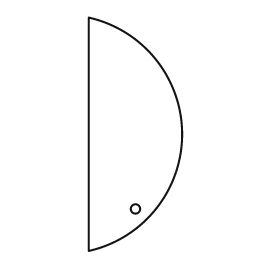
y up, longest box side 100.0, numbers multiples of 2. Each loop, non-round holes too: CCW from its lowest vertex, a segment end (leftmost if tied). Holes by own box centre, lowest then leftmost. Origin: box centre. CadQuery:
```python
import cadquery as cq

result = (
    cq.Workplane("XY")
    .moveTo(-20.0, -50.0)
    .threePointArc((20.0, 0.0), (-20.0, 50.0))
    .close()
    .moveTo(0.0, -32.0)
    .circle(2.0)
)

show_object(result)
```